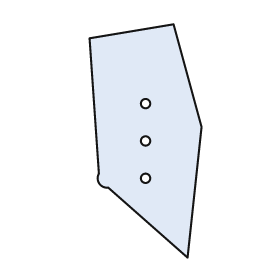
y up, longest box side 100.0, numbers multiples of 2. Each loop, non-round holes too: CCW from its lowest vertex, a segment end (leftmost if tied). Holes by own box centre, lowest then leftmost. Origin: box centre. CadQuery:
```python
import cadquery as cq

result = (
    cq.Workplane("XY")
    .moveTo(18.0, -50.0)
    .lineTo(24.0, 6.0)
    .lineTo(12.0, 50.0)
    .lineTo(-24.0, 44.0)
    .lineTo(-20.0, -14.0)
    .threePointArc((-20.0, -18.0), (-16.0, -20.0))
    .close()
    .moveTo(0.0, -16.0)
    .circle(2.0)
    .moveTo(0.0, 0.0)
    .circle(2.0)
    .moveTo(0.0, 16.0)
    .circle(2.0)
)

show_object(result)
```